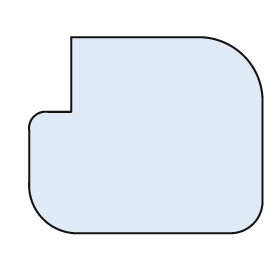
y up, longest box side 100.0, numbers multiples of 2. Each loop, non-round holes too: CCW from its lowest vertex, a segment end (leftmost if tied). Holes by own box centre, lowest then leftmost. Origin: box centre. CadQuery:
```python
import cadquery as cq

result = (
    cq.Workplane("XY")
    .moveTo(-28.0, -42.0)
    .lineTo(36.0, -42.0)
    .threePointArc((46.0, -38.0), (50.0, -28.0))
    .lineTo(50.0, 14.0)
    .threePointArc((42.0, 34.0), (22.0, 42.0))
    .lineTo(-32.0, 42.0)
    .lineTo(-32.0, 10.0)
    .lineTo(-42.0, 10.0)
    .threePointArc((-48.0, 8.0), (-50.0, 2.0))
    .lineTo(-50.0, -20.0)
    .threePointArc((-44.0, -36.0), (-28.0, -42.0))
    .close()
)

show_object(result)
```